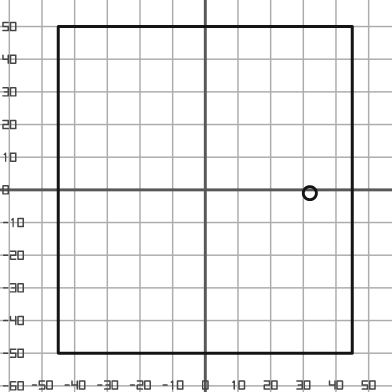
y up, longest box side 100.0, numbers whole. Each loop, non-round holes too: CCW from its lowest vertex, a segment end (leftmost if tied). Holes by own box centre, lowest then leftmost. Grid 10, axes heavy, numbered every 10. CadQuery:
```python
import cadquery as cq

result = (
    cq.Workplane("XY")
    .moveTo(-45.0, -50.0)
    .lineTo(45.0, -50.0)
    .lineTo(45.0, 50.0)
    .lineTo(-45.0, 50.0)
    .close()
    .moveTo(32.0, -1.0)
    .circle(2.0)
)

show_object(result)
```